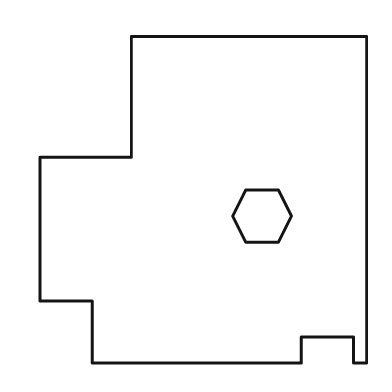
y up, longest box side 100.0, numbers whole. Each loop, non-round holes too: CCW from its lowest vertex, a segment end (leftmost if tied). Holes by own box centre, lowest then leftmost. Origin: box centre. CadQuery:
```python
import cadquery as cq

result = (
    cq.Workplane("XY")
    .moveTo(-34.0, -50.0)
    .lineTo(30.0, -50.0)
    .lineTo(30.0, -42.0)
    .lineTo(46.0, -42.0)
    .lineTo(46.0, -50.0)
    .lineTo(50.0, -50.0)
    .lineTo(50.0, 50.0)
    .lineTo(-22.0, 50.0)
    .lineTo(-22.0, 13.0)
    .lineTo(-50.0, 13.0)
    .lineTo(-50.0, -31.0)
    .lineTo(-34.0, -31.0)
    .close()
    .moveTo(13.0, -13.0)
    .lineTo(23.0, -13.0)
    .lineTo(27.0, -5.0)
    .lineTo(23.0, 3.0)
    .lineTo(13.0, 3.0)
    .lineTo(9.0, -5.0)
    .close()
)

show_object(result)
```